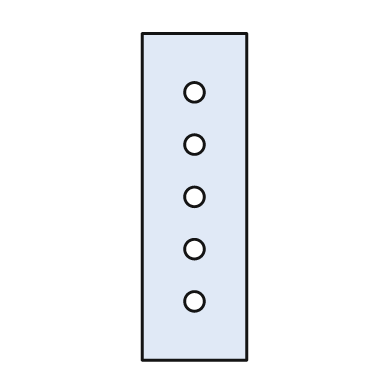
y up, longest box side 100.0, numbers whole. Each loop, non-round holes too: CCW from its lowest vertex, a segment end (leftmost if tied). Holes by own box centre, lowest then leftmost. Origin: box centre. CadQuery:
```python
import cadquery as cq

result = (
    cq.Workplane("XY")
    .moveTo(-16.0, -50.0)
    .lineTo(16.0, -50.0)
    .lineTo(16.0, 50.0)
    .lineTo(-16.0, 50.0)
    .close()
    .moveTo(0.0, -32.0)
    .circle(3.0)
    .moveTo(0.0, -16.0)
    .circle(3.0)
    .moveTo(0.0, 0.0)
    .circle(3.0)
    .moveTo(0.0, 16.0)
    .circle(3.0)
    .moveTo(0.0, 32.0)
    .circle(3.0)
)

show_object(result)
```